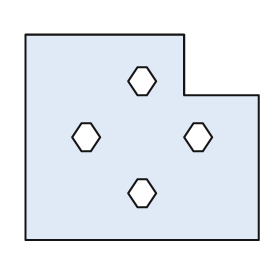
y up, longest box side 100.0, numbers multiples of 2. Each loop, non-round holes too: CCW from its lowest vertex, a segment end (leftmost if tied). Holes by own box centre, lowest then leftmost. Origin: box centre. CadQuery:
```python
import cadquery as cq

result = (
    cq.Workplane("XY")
    .moveTo(-50.0, -44.0)
    .lineTo(50.0, -44.0)
    .lineTo(50.0, 18.0)
    .lineTo(18.0, 18.0)
    .lineTo(18.0, 44.0)
    .lineTo(-50.0, 44.0)
    .close()
    .moveTo(-2.0, -30.0)
    .lineTo(2.0, -30.0)
    .lineTo(6.0, -24.0)
    .lineTo(2.0, -18.0)
    .lineTo(-2.0, -18.0)
    .lineTo(-6.0, -24.0)
    .close()
    .moveTo(-26.0, -6.0)
    .lineTo(-22.0, -6.0)
    .lineTo(-18.0, 0.0)
    .lineTo(-22.0, 6.0)
    .lineTo(-26.0, 6.0)
    .lineTo(-30.0, 0.0)
    .close()
    .moveTo(22.0, -6.0)
    .lineTo(26.0, -6.0)
    .lineTo(30.0, 0.0)
    .lineTo(26.0, 6.0)
    .lineTo(22.0, 6.0)
    .lineTo(18.0, 0.0)
    .close()
    .moveTo(-2.0, 18.0)
    .lineTo(2.0, 18.0)
    .lineTo(6.0, 24.0)
    .lineTo(2.0, 30.0)
    .lineTo(-2.0, 30.0)
    .lineTo(-6.0, 24.0)
    .close()
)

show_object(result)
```